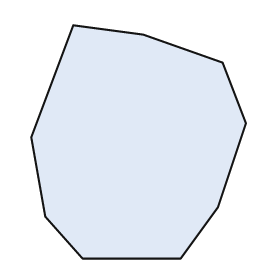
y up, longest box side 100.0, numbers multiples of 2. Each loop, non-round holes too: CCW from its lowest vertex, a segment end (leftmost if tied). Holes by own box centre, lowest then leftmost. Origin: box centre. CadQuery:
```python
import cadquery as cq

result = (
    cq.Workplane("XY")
    .moveTo(-24.0, -50.0)
    .lineTo(18.0, -50.0)
    .lineTo(34.0, -28.0)
    .lineTo(46.0, 8.0)
    .lineTo(36.0, 34.0)
    .lineTo(2.0, 46.0)
    .lineTo(-28.0, 50.0)
    .lineTo(-46.0, 2.0)
    .lineTo(-40.0, -32.0)
    .close()
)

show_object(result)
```